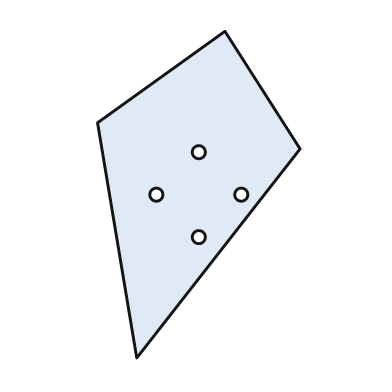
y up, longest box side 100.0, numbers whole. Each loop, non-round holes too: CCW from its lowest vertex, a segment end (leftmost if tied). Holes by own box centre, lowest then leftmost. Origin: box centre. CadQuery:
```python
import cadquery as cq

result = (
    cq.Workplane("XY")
    .moveTo(-19.0, -50.0)
    .lineTo(31.0, 14.0)
    .lineTo(8.0, 50.0)
    .lineTo(-31.0, 22.0)
    .close()
    .moveTo(0.0, -13.0)
    .circle(2.0)
    .moveTo(-13.0, 0.0)
    .circle(2.0)
    .moveTo(13.0, 0.0)
    .circle(2.0)
    .moveTo(0.0, 13.0)
    .circle(2.0)
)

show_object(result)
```